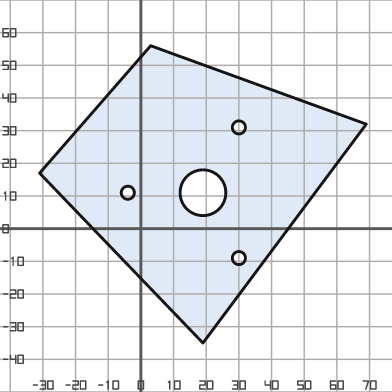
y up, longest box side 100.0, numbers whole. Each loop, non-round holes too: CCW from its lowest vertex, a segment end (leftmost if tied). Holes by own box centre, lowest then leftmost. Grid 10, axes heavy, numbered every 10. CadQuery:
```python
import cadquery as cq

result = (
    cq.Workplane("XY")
    .moveTo(19.0, -35.0)
    .lineTo(69.0, 32.0)
    .lineTo(3.0, 56.0)
    .lineTo(-31.0, 17.0)
    .close()
    .moveTo(30.0, -9.0)
    .circle(2.0)
    .moveTo(-4.0, 11.0)
    .circle(2.0)
    .moveTo(19.0, 11.0)
    .circle(7.0)
    .moveTo(30.0, 31.0)
    .circle(2.0)
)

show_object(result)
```